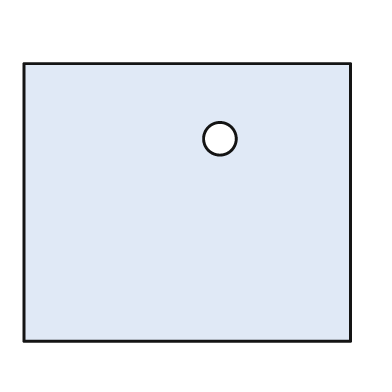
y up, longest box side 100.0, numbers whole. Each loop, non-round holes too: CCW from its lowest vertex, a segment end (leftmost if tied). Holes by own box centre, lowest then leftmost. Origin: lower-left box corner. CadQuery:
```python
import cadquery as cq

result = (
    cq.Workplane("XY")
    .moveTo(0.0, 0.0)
    .lineTo(100.0, 0.0)
    .lineTo(100.0, 85.0)
    .lineTo(0.0, 85.0)
    .close()
    .moveTo(60.0, 62.0)
    .circle(5.0)
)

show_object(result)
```